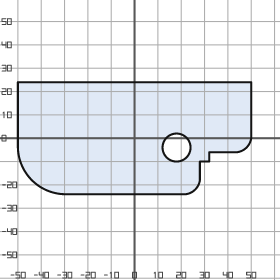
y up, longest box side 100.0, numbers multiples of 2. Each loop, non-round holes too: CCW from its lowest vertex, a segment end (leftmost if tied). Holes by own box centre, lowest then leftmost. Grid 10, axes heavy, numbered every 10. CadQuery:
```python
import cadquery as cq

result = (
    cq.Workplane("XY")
    .moveTo(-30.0, -24.0)
    .lineTo(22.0, -24.0)
    .threePointArc((26.0, -22.0), (28.0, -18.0))
    .lineTo(28.0, -10.0)
    .lineTo(32.0, -10.0)
    .lineTo(32.0, -6.0)
    .lineTo(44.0, -6.0)
    .threePointArc((48.0, -4.0), (50.0, 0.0))
    .lineTo(50.0, 24.0)
    .lineTo(-50.0, 24.0)
    .lineTo(-50.0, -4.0)
    .threePointArc((-44.0, -18.0), (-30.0, -24.0))
    .close()
    .moveTo(18.0, -4.0)
    .circle(6.0)
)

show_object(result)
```